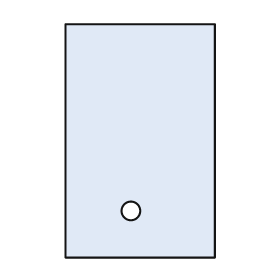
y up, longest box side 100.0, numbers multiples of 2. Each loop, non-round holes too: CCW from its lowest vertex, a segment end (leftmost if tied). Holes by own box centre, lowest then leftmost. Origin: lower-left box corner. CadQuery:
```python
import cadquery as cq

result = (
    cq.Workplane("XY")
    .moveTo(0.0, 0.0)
    .lineTo(64.0, 0.0)
    .lineTo(64.0, 100.0)
    .lineTo(0.0, 100.0)
    .close()
    .moveTo(28.0, 20.0)
    .circle(4.0)
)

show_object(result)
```